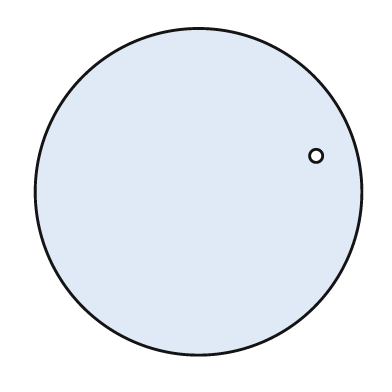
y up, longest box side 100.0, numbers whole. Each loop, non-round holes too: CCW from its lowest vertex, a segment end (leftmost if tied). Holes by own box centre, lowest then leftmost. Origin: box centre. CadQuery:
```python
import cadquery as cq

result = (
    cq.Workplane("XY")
    .moveTo(0.0, 0.0)
    .circle(50.0)
    .moveTo(36.0, 11.0)
    .circle(2.0)
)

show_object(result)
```